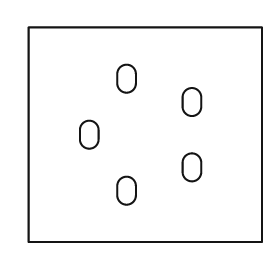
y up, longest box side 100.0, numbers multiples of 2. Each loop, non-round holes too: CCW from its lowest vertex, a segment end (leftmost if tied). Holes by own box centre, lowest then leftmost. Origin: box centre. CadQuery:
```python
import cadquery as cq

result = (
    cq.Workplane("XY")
    .moveTo(-50.0, -46.0)
    .lineTo(50.0, -46.0)
    .lineTo(50.0, 46.0)
    .lineTo(-50.0, 46.0)
    .close()
    .moveTo(-12.0, -26.0)
    .threePointArc((-8.0, -30.0), (-4.0, -26.0))
    .lineTo(-4.0, -22.0)
    .threePointArc((-8.0, -18.0), (-12.0, -22.0))
    .close()
    .moveTo(16.0, -16.0)
    .threePointArc((20.0, -20.0), (24.0, -16.0))
    .lineTo(24.0, -12.0)
    .threePointArc((20.0, -8.0), (16.0, -12.0))
    .close()
    .moveTo(-28.0, -2.0)
    .threePointArc((-24.0, -6.0), (-20.0, -2.0))
    .lineTo(-20.0, 2.0)
    .threePointArc((-24.0, 6.0), (-28.0, 2.0))
    .close()
    .moveTo(16.0, 12.0)
    .threePointArc((20.0, 8.0), (24.0, 12.0))
    .lineTo(24.0, 16.0)
    .threePointArc((20.0, 20.0), (16.0, 16.0))
    .close()
    .moveTo(-12.0, 22.0)
    .threePointArc((-8.0, 18.0), (-4.0, 22.0))
    .lineTo(-4.0, 26.0)
    .threePointArc((-8.0, 30.0), (-12.0, 26.0))
    .close()
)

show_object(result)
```